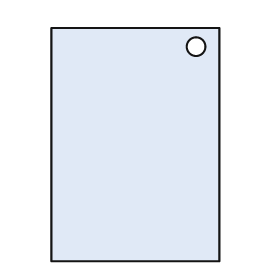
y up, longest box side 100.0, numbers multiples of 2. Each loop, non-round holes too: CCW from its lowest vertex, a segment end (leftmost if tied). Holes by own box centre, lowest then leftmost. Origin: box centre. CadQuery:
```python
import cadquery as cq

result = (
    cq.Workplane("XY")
    .moveTo(-36.0, -50.0)
    .lineTo(36.0, -50.0)
    .lineTo(36.0, 50.0)
    .lineTo(-36.0, 50.0)
    .close()
    .moveTo(26.0, 42.0)
    .circle(4.0)
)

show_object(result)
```